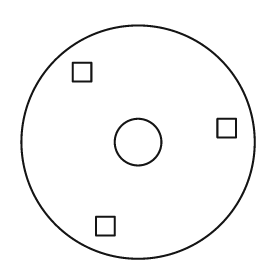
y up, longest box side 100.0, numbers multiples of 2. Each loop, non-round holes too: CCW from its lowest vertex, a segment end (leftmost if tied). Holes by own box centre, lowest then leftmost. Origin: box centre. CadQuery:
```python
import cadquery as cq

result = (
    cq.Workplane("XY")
    .moveTo(0.0, 0.0)
    .circle(50.0)
    .moveTo(-18.0, -40.0)
    .lineTo(-10.0, -40.0)
    .lineTo(-10.0, -32.0)
    .lineTo(-18.0, -32.0)
    .close()
    .moveTo(0.0, 0.0)
    .circle(10.0)
    .moveTo(34.0, 2.0)
    .lineTo(42.0, 2.0)
    .lineTo(42.0, 10.0)
    .lineTo(34.0, 10.0)
    .close()
    .moveTo(-28.0, 26.0)
    .lineTo(-20.0, 26.0)
    .lineTo(-20.0, 34.0)
    .lineTo(-28.0, 34.0)
    .close()
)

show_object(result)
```